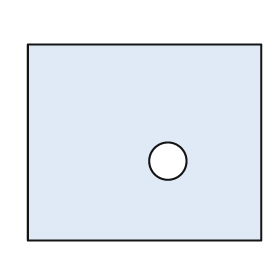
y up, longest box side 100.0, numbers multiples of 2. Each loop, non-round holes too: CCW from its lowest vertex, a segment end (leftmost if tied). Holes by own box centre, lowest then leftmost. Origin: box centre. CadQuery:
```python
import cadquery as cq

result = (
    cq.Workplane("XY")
    .moveTo(-50.0, -42.0)
    .lineTo(50.0, -42.0)
    .lineTo(50.0, 42.0)
    .lineTo(-50.0, 42.0)
    .close()
    .moveTo(10.0, -8.0)
    .circle(8.0)
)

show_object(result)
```